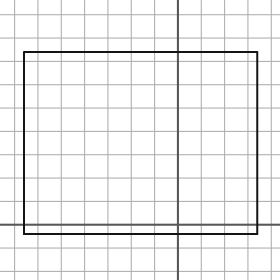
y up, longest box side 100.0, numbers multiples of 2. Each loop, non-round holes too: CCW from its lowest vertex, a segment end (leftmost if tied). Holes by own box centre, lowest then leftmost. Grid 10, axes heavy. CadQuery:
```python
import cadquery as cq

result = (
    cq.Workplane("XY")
    .moveTo(-66.0, -4.0)
    .lineTo(34.0, -4.0)
    .lineTo(34.0, 74.0)
    .lineTo(-66.0, 74.0)
    .close()
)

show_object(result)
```